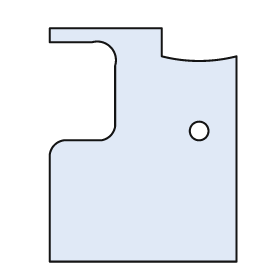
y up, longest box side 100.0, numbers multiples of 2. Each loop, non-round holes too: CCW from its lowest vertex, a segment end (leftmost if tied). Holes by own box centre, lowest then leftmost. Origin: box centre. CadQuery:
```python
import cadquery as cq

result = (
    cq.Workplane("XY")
    .moveTo(-40.0, -50.0)
    .lineTo(40.0, -50.0)
    .lineTo(40.0, 38.0)
    .threePointArc((24.0, 36.0), (8.0, 38.0))
    .lineTo(8.0, 50.0)
    .lineTo(-40.0, 50.0)
    .lineTo(-40.0, 44.0)
    .lineTo(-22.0, 44.0)
    .threePointArc((-14.0, 42.0), (-12.0, 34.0))
    .lineTo(-12.0, 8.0)
    .threePointArc((-14.0, 4.0), (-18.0, 2.0))
    .lineTo(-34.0, 2.0)
    .threePointArc((-38.0, 0.0), (-40.0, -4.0))
    .close()
    .moveTo(24.0, 6.0)
    .circle(4.0)
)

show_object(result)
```